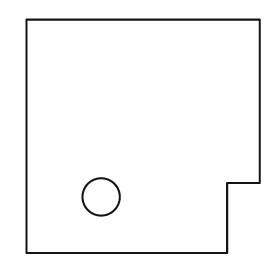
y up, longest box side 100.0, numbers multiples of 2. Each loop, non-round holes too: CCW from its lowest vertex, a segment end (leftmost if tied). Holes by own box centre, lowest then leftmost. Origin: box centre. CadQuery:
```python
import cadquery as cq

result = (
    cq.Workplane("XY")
    .moveTo(-50.0, -50.0)
    .lineTo(36.0, -50.0)
    .lineTo(36.0, -20.0)
    .lineTo(50.0, -20.0)
    .lineTo(50.0, 50.0)
    .lineTo(-50.0, 50.0)
    .close()
    .moveTo(-18.0, -26.0)
    .circle(8.0)
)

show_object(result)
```